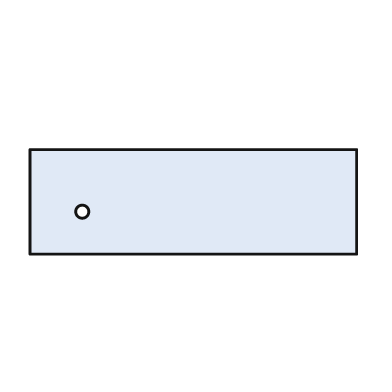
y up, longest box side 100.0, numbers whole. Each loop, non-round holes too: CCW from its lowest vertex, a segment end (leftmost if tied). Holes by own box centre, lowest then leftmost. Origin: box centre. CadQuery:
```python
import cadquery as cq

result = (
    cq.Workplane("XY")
    .moveTo(-50.0, -16.0)
    .lineTo(50.0, -16.0)
    .lineTo(50.0, 16.0)
    .lineTo(-50.0, 16.0)
    .close()
    .moveTo(-34.0, -3.0)
    .circle(2.0)
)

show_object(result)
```